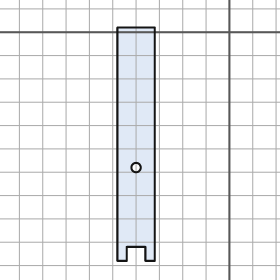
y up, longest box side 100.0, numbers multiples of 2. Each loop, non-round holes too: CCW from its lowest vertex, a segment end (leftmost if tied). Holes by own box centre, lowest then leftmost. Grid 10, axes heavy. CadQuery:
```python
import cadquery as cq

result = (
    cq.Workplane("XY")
    .moveTo(-48.0, -98.0)
    .lineTo(-44.0, -98.0)
    .lineTo(-44.0, -92.0)
    .lineTo(-36.0, -92.0)
    .lineTo(-36.0, -98.0)
    .lineTo(-32.0, -98.0)
    .lineTo(-32.0, 2.0)
    .lineTo(-48.0, 2.0)
    .close()
    .moveTo(-40.0, -58.0)
    .circle(2.0)
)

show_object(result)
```